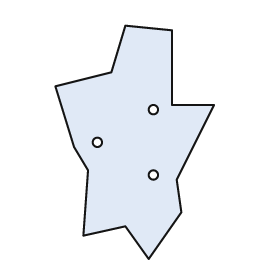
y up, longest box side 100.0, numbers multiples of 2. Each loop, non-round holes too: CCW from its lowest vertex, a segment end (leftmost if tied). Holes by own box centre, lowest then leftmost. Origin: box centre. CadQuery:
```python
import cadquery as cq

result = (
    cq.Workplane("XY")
    .moveTo(6.0, -50.0)
    .lineTo(20.0, -30.0)
    .lineTo(18.0, -16.0)
    .lineTo(34.0, 16.0)
    .lineTo(16.0, 16.0)
    .lineTo(16.0, 48.0)
    .lineTo(-4.0, 50.0)
    .lineTo(-10.0, 30.0)
    .lineTo(-34.0, 24.0)
    .lineTo(-26.0, -2.0)
    .lineTo(-20.0, -12.0)
    .lineTo(-22.0, -40.0)
    .lineTo(-4.0, -36.0)
    .close()
    .moveTo(8.0, -14.0)
    .circle(2.0)
    .moveTo(-16.0, 0.0)
    .circle(2.0)
    .moveTo(8.0, 14.0)
    .circle(2.0)
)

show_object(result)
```